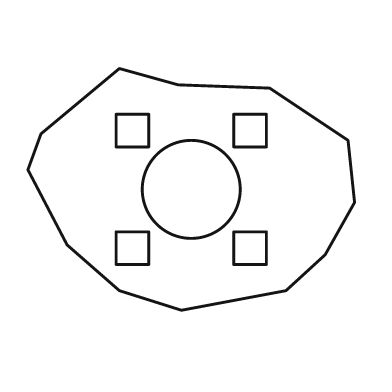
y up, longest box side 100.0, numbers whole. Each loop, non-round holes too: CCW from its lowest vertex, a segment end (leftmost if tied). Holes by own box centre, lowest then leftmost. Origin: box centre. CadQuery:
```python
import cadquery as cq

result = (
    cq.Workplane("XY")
    .moveTo(-3.0, -37.0)
    .lineTo(29.0, -31.0)
    .lineTo(41.0, -20.0)
    .lineTo(50.0, -4.0)
    .lineTo(48.0, 15.0)
    .lineTo(24.0, 31.0)
    .lineTo(-4.0, 32.0)
    .lineTo(-22.0, 37.0)
    .lineTo(-46.0, 17.0)
    .lineTo(-50.0, 6.0)
    .lineTo(-38.0, -17.0)
    .lineTo(-22.0, -31.0)
    .close()
    .moveTo(-23.0, -23.0)
    .lineTo(-13.0, -23.0)
    .lineTo(-13.0, -13.0)
    .lineTo(-23.0, -13.0)
    .close()
    .moveTo(13.0, -23.0)
    .lineTo(23.0, -23.0)
    .lineTo(23.0, -13.0)
    .lineTo(13.0, -13.0)
    .close()
    .moveTo(0.0, 0.0)
    .circle(15.0)
    .moveTo(-23.0, 13.0)
    .lineTo(-13.0, 13.0)
    .lineTo(-13.0, 23.0)
    .lineTo(-23.0, 23.0)
    .close()
    .moveTo(13.0, 13.0)
    .lineTo(23.0, 13.0)
    .lineTo(23.0, 23.0)
    .lineTo(13.0, 23.0)
    .close()
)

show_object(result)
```